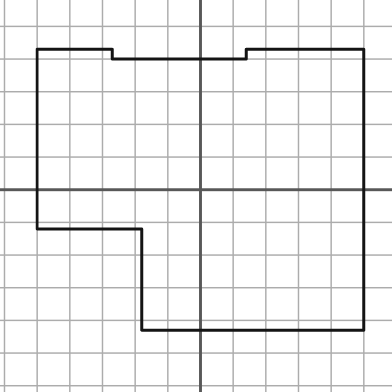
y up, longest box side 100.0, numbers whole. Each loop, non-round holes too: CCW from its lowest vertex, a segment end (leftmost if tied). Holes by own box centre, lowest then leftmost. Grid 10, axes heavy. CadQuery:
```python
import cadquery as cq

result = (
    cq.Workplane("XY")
    .moveTo(-18.0, -43.0)
    .lineTo(50.0, -43.0)
    .lineTo(50.0, 43.0)
    .lineTo(14.0, 43.0)
    .lineTo(14.0, 40.0)
    .lineTo(-27.0, 40.0)
    .lineTo(-27.0, 43.0)
    .lineTo(-50.0, 43.0)
    .lineTo(-50.0, -12.0)
    .lineTo(-18.0, -12.0)
    .close()
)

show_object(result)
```